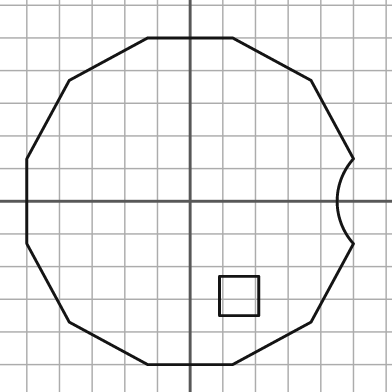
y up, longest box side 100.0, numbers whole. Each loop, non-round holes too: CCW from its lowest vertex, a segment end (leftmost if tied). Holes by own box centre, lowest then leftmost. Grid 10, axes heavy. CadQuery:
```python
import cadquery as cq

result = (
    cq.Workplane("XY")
    .moveTo(-13.0, -50.0)
    .lineTo(13.0, -50.0)
    .lineTo(37.0, -37.0)
    .lineTo(50.0, -13.0)
    .threePointArc((45.0, 0.0), (50.0, 13.0))
    .lineTo(37.0, 37.0)
    .lineTo(13.0, 50.0)
    .lineTo(-13.0, 50.0)
    .lineTo(-37.0, 37.0)
    .lineTo(-50.0, 13.0)
    .lineTo(-50.0, -13.0)
    .lineTo(-37.0, -37.0)
    .close()
    .moveTo(9.0, -35.0)
    .lineTo(21.0, -35.0)
    .lineTo(21.0, -23.0)
    .lineTo(9.0, -23.0)
    .close()
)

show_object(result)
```